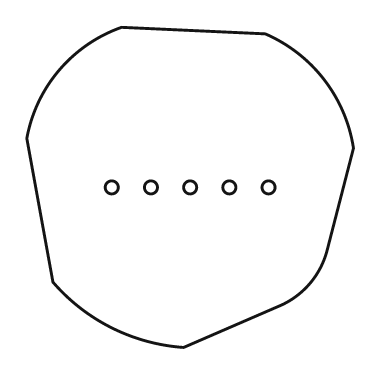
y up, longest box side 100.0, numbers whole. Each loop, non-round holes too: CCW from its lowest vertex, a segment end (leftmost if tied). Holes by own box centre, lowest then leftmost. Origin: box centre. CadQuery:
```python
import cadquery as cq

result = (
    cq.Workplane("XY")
    .moveTo(-2.0, -49.0)
    .lineTo(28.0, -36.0)
    .threePointArc((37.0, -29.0), (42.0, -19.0))
    .lineTo(50.0, 12.0)
    .threePointArc((41.0, 33.0), (23.0, 47.0))
    .lineTo(-21.0, 49.0)
    .threePointArc((-40.0, 36.0), (-50.0, 15.0))
    .lineTo(-42.0, -29.0)
    .threePointArc((-24.0, -43.0), (-2.0, -49.0))
    .close()
    .moveTo(-24.0, 0.0)
    .circle(2.0)
    .moveTo(-12.0, 0.0)
    .circle(2.0)
    .moveTo(0.0, 0.0)
    .circle(2.0)
    .moveTo(12.0, 0.0)
    .circle(2.0)
    .moveTo(24.0, 0.0)
    .circle(2.0)
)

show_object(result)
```